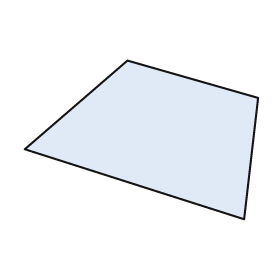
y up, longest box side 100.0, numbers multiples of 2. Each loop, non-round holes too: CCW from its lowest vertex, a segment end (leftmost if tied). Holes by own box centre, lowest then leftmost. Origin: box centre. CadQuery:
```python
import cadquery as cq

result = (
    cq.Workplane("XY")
    .moveTo(44.0, -34.0)
    .lineTo(50.0, 18.0)
    .lineTo(-6.0, 34.0)
    .lineTo(-50.0, -4.0)
    .close()
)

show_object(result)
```